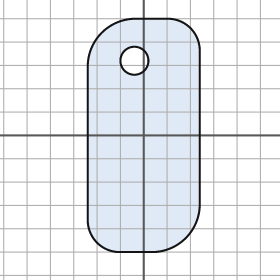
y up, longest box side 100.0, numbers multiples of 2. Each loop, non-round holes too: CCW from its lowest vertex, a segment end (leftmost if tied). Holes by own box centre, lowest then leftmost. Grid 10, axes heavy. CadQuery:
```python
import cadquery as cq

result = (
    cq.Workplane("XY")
    .moveTo(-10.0, -50.0)
    .lineTo(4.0, -50.0)
    .threePointArc((18.0, -44.0), (24.0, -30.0))
    .lineTo(24.0, 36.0)
    .threePointArc((20.0, 46.0), (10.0, 50.0))
    .lineTo(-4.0, 50.0)
    .threePointArc((-18.0, 44.0), (-24.0, 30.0))
    .lineTo(-24.0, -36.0)
    .threePointArc((-20.0, -46.0), (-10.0, -50.0))
    .close()
    .moveTo(-4.0, 32.0)
    .circle(6.0)
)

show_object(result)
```